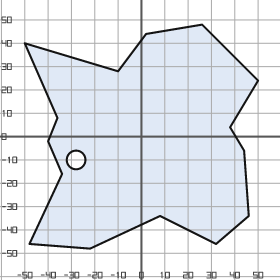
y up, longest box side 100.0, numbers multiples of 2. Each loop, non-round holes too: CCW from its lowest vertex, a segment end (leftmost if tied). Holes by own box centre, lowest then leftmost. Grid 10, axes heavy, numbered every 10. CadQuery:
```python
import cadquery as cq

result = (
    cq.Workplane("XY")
    .moveTo(-22.0, -48.0)
    .lineTo(8.0, -34.0)
    .lineTo(32.0, -46.0)
    .lineTo(46.0, -34.0)
    .lineTo(44.0, -6.0)
    .lineTo(38.0, 4.0)
    .lineTo(50.0, 24.0)
    .lineTo(26.0, 48.0)
    .lineTo(2.0, 44.0)
    .lineTo(-10.0, 28.0)
    .lineTo(-50.0, 40.0)
    .lineTo(-36.0, 8.0)
    .lineTo(-40.0, -2.0)
    .lineTo(-34.0, -16.0)
    .lineTo(-48.0, -46.0)
    .close()
    .moveTo(-28.0, -10.0)
    .circle(4.0)
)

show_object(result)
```